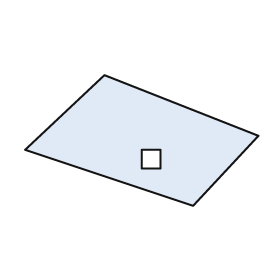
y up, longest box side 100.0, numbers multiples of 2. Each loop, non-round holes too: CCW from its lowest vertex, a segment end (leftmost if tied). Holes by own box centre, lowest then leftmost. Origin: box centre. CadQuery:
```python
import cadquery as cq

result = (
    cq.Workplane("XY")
    .moveTo(22.0, -28.0)
    .lineTo(50.0, 2.0)
    .lineTo(-16.0, 28.0)
    .lineTo(-50.0, -4.0)
    .close()
    .moveTo(0.0, -12.0)
    .lineTo(8.0, -12.0)
    .lineTo(8.0, -4.0)
    .lineTo(0.0, -4.0)
    .close()
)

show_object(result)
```